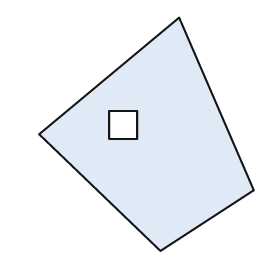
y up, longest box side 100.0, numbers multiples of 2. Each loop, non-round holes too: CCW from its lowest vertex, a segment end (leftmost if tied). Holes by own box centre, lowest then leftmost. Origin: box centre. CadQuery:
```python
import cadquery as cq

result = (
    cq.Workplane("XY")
    .moveTo(6.0, -50.0)
    .lineTo(46.0, -24.0)
    .lineTo(14.0, 50.0)
    .lineTo(-46.0, 0.0)
    .close()
    .moveTo(-16.0, -2.0)
    .lineTo(-4.0, -2.0)
    .lineTo(-4.0, 10.0)
    .lineTo(-16.0, 10.0)
    .close()
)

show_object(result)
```